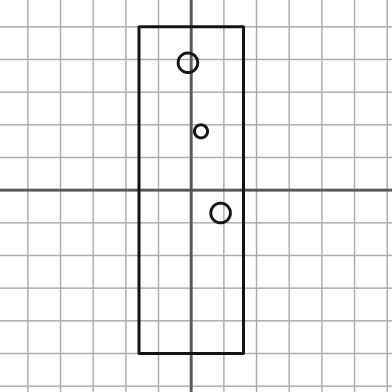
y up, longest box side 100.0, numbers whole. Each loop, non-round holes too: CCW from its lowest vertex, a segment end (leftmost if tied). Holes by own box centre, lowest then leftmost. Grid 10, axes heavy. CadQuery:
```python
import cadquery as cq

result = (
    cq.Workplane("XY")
    .moveTo(-16.0, -50.0)
    .lineTo(16.0, -50.0)
    .lineTo(16.0, 50.0)
    .lineTo(-16.0, 50.0)
    .close()
    .moveTo(9.0, -7.0)
    .circle(3.0)
    .moveTo(3.0, 18.0)
    .circle(2.0)
    .moveTo(-1.0, 39.0)
    .circle(3.0)
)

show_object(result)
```